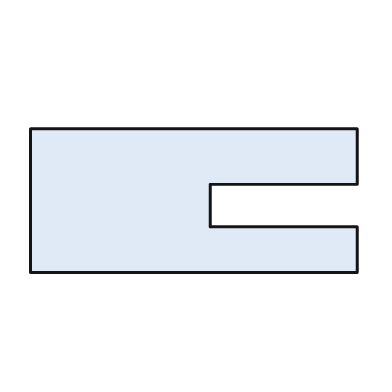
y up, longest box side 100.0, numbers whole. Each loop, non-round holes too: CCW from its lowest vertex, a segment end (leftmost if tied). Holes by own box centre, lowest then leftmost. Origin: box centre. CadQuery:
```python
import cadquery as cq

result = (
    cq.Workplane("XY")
    .moveTo(-50.0, -22.0)
    .lineTo(50.0, -22.0)
    .lineTo(50.0, -8.0)
    .lineTo(5.0, -8.0)
    .lineTo(5.0, 5.0)
    .lineTo(50.0, 5.0)
    .lineTo(50.0, 22.0)
    .lineTo(-50.0, 22.0)
    .close()
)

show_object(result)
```